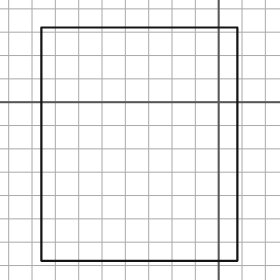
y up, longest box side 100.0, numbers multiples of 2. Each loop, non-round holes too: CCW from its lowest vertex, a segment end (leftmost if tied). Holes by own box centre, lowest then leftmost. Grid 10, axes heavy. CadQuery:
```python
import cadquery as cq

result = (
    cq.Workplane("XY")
    .moveTo(-76.0, -68.0)
    .lineTo(8.0, -68.0)
    .lineTo(8.0, 32.0)
    .lineTo(-76.0, 32.0)
    .close()
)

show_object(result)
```